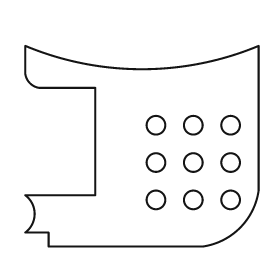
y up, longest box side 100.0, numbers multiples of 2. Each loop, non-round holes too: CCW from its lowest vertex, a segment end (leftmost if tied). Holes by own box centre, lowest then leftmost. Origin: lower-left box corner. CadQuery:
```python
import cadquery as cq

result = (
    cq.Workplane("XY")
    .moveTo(10.0, 0.0)
    .lineTo(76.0, 0.0)
    .threePointArc((92.0, 8.0), (100.0, 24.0))
    .lineTo(100.0, 86.0)
    .threePointArc((50.0, 76.0), (0.0, 86.0))
    .lineTo(0.0, 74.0)
    .threePointArc((2.0, 70.0), (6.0, 68.0))
    .lineTo(30.0, 68.0)
    .lineTo(30.0, 22.0)
    .lineTo(0.0, 22.0)
    .threePointArc((4.0, 14.0), (0.0, 6.0))
    .lineTo(10.0, 6.0)
    .close()
    .moveTo(56.0, 20.0)
    .circle(4.0)
    .moveTo(72.0, 20.0)
    .circle(4.0)
    .moveTo(88.0, 20.0)
    .circle(4.0)
    .moveTo(56.0, 36.0)
    .circle(4.0)
    .moveTo(72.0, 36.0)
    .circle(4.0)
    .moveTo(88.0, 36.0)
    .circle(4.0)
    .moveTo(56.0, 52.0)
    .circle(4.0)
    .moveTo(72.0, 52.0)
    .circle(4.0)
    .moveTo(88.0, 52.0)
    .circle(4.0)
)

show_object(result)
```